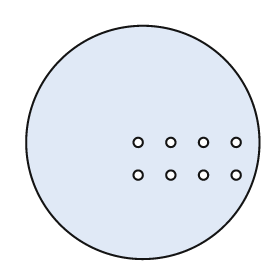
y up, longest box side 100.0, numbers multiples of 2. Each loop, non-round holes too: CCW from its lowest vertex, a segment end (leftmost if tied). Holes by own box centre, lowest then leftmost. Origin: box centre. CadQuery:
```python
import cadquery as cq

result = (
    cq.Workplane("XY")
    .moveTo(0.0, 0.0)
    .circle(50.0)
    .moveTo(-2.0, -14.0)
    .circle(2.0)
    .moveTo(12.0, -14.0)
    .circle(2.0)
    .moveTo(26.0, -14.0)
    .circle(2.0)
    .moveTo(40.0, -14.0)
    .circle(2.0)
    .moveTo(-2.0, 0.0)
    .circle(2.0)
    .moveTo(12.0, 0.0)
    .circle(2.0)
    .moveTo(26.0, 0.0)
    .circle(2.0)
    .moveTo(40.0, 0.0)
    .circle(2.0)
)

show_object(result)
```